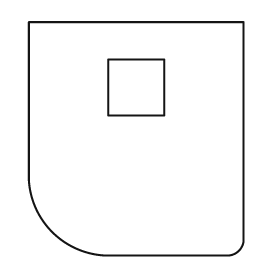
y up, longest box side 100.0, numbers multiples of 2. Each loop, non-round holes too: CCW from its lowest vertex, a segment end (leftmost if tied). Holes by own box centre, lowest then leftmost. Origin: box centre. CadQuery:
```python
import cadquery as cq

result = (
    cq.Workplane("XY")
    .moveTo(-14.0, -50.0)
    .lineTo(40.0, -50.0)
    .threePointArc((44.0, -48.0), (46.0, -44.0))
    .lineTo(46.0, 50.0)
    .lineTo(-46.0, 50.0)
    .lineTo(-46.0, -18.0)
    .threePointArc((-36.0, -40.0), (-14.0, -50.0))
    .close()
    .moveTo(-12.0, 10.0)
    .lineTo(12.0, 10.0)
    .lineTo(12.0, 34.0)
    .lineTo(-12.0, 34.0)
    .close()
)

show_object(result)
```